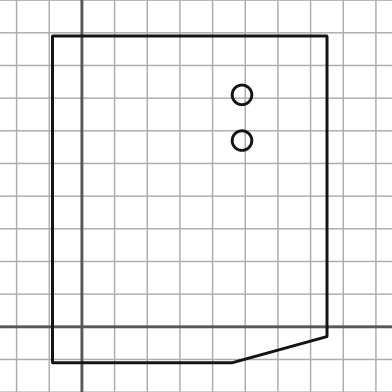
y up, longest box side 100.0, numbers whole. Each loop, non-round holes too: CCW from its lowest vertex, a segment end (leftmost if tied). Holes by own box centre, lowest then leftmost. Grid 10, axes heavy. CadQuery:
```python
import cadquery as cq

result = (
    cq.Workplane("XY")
    .moveTo(-9.0, -11.0)
    .lineTo(46.0, -11.0)
    .lineTo(75.0, -3.0)
    .lineTo(75.0, 89.0)
    .lineTo(-9.0, 89.0)
    .close()
    .moveTo(49.0, 57.0)
    .circle(3.0)
    .moveTo(49.0, 71.0)
    .circle(3.0)
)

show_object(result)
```